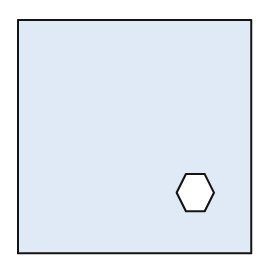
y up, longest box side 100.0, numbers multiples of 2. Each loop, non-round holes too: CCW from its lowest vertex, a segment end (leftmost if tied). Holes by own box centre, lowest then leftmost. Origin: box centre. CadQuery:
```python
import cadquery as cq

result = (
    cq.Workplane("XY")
    .moveTo(-50.0, -50.0)
    .lineTo(50.0, -50.0)
    .lineTo(50.0, 50.0)
    .lineTo(-50.0, 50.0)
    .close()
    .moveTo(22.0, -32.0)
    .lineTo(30.0, -32.0)
    .lineTo(34.0, -24.0)
    .lineTo(30.0, -16.0)
    .lineTo(22.0, -16.0)
    .lineTo(18.0, -24.0)
    .close()
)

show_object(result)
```